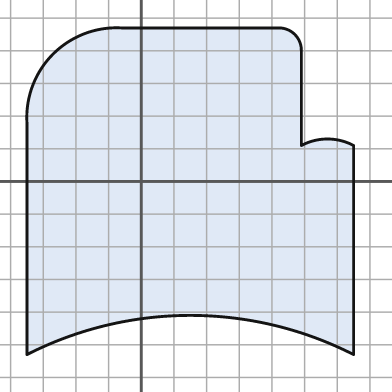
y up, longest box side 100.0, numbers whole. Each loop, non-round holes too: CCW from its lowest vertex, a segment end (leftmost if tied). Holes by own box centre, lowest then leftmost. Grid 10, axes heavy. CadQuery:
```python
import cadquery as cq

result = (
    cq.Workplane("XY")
    .moveTo(-35.0, -53.0)
    .threePointArc((15.0, -41.0), (65.0, -53.0))
    .lineTo(65.0, 11.0)
    .threePointArc((57.0, 13.0), (49.0, 11.0))
    .lineTo(49.0, 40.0)
    .threePointArc((47.0, 45.0), (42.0, 47.0))
    .lineTo(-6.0, 47.0)
    .threePointArc((-27.0, 39.0), (-35.0, 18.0))
    .close()
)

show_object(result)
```